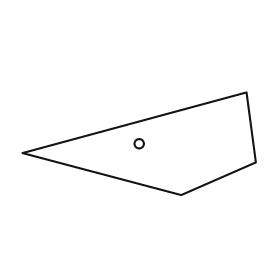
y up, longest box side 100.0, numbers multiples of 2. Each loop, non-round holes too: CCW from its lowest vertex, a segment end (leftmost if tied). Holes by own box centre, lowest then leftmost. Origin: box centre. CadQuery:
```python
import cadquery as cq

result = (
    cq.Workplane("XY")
    .moveTo(18.0, -22.0)
    .lineTo(50.0, -8.0)
    .lineTo(46.0, 22.0)
    .lineTo(-50.0, -4.0)
    .close()
    .moveTo(0.0, 0.0)
    .circle(2.0)
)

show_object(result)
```